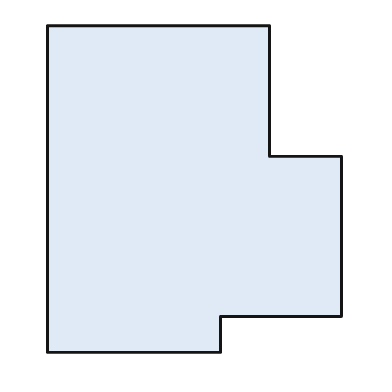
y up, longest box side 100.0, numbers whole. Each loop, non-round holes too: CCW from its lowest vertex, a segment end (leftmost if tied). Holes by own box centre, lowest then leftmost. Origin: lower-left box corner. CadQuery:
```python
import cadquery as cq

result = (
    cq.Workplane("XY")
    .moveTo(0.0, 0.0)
    .lineTo(53.0, 0.0)
    .lineTo(53.0, 11.0)
    .lineTo(90.0, 11.0)
    .lineTo(90.0, 60.0)
    .lineTo(68.0, 60.0)
    .lineTo(68.0, 100.0)
    .lineTo(0.0, 100.0)
    .close()
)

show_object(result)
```